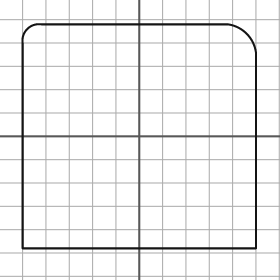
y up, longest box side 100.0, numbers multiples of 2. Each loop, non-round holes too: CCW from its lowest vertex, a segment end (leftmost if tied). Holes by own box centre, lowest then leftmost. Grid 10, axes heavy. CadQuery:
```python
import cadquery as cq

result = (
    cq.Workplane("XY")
    .moveTo(-50.0, -48.0)
    .lineTo(50.0, -48.0)
    .lineTo(50.0, 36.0)
    .threePointArc((46.0, 44.0), (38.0, 48.0))
    .lineTo(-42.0, 48.0)
    .threePointArc((-48.0, 46.0), (-50.0, 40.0))
    .close()
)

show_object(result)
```